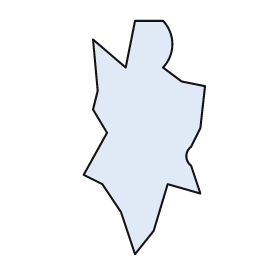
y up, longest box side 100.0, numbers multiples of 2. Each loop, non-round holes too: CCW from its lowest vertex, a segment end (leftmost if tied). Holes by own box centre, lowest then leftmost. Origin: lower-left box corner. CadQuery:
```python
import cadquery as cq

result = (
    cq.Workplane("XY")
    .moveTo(22.0, 0.0)
    .lineTo(30.0, 10.0)
    .lineTo(36.0, 30.0)
    .lineTo(50.0, 26.0)
    .lineTo(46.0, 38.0)
    .threePointArc((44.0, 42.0), (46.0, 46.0))
    .lineTo(50.0, 54.0)
    .lineTo(52.0, 72.0)
    .lineTo(42.0, 74.0)
    .lineTo(34.0, 80.0)
    .threePointArc((38.0, 90.0), (34.0, 100.0))
    .lineTo(22.0, 100.0)
    .lineTo(18.0, 80.0)
    .lineTo(4.0, 92.0)
    .lineTo(6.0, 70.0)
    .lineTo(4.0, 62.0)
    .lineTo(10.0, 52.0)
    .lineTo(0.0, 34.0)
    .lineTo(8.0, 30.0)
    .lineTo(16.0, 18.0)
    .close()
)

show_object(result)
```